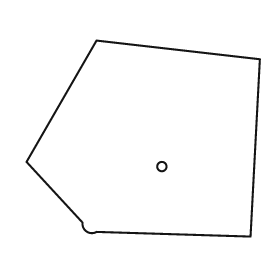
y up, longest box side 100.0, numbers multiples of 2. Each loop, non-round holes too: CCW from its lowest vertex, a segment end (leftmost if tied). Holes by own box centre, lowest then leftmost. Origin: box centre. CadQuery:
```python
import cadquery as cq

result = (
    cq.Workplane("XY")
    .moveTo(46.0, -42.0)
    .lineTo(50.0, 34.0)
    .lineTo(-20.0, 42.0)
    .lineTo(-50.0, -10.0)
    .lineTo(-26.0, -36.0)
    .threePointArc((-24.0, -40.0), (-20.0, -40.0))
    .close()
    .moveTo(8.0, -12.0)
    .circle(2.0)
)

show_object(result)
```